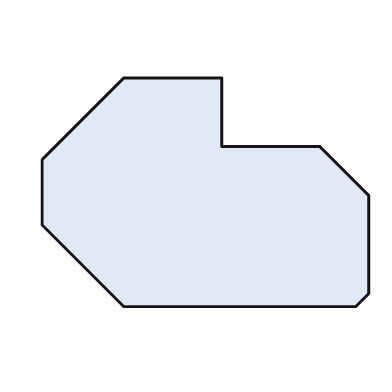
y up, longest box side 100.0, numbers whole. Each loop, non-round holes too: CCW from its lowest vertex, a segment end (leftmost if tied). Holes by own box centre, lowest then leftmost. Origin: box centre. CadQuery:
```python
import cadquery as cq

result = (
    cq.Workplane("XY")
    .moveTo(-25.0, -35.0)
    .lineTo(46.0, -35.0)
    .lineTo(50.0, -31.0)
    .lineTo(50.0, -1.0)
    .lineTo(35.0, 14.0)
    .lineTo(5.0, 14.0)
    .lineTo(5.0, 35.0)
    .lineTo(-25.0, 35.0)
    .lineTo(-50.0, 10.0)
    .lineTo(-50.0, -10.0)
    .close()
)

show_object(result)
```